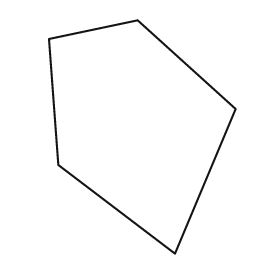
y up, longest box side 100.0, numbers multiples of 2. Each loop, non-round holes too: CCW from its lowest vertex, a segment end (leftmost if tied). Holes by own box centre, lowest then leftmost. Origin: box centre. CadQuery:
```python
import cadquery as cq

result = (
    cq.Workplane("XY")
    .moveTo(14.0, -50.0)
    .lineTo(40.0, 12.0)
    .lineTo(-2.0, 50.0)
    .lineTo(-40.0, 42.0)
    .lineTo(-36.0, -12.0)
    .close()
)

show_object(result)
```